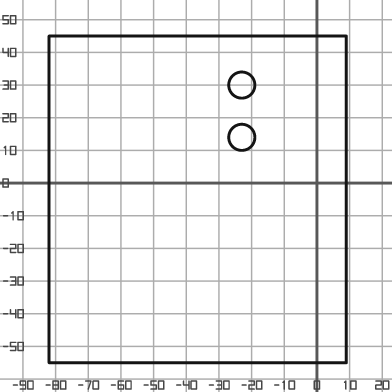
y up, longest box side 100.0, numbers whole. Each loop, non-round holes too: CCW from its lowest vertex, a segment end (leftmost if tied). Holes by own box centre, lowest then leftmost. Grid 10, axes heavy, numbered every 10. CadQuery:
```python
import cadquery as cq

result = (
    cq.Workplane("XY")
    .moveTo(-82.0, -55.0)
    .lineTo(9.0, -55.0)
    .lineTo(9.0, 45.0)
    .lineTo(-82.0, 45.0)
    .close()
    .moveTo(-23.0, 14.0)
    .circle(4.0)
    .moveTo(-23.0, 30.0)
    .circle(4.0)
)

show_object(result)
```